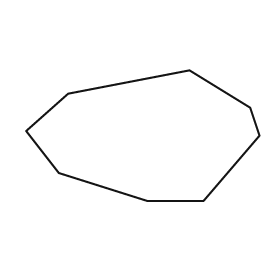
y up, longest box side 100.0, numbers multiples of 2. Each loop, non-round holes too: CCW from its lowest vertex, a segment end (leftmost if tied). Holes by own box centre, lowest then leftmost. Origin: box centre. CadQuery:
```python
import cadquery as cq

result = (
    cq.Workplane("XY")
    .moveTo(2.0, -28.0)
    .lineTo(26.0, -28.0)
    .lineTo(50.0, 0.0)
    .lineTo(46.0, 12.0)
    .lineTo(20.0, 28.0)
    .lineTo(-32.0, 18.0)
    .lineTo(-50.0, 2.0)
    .lineTo(-36.0, -16.0)
    .close()
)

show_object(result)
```